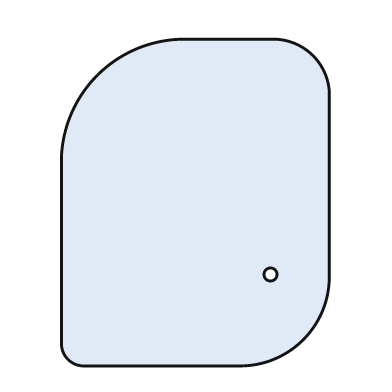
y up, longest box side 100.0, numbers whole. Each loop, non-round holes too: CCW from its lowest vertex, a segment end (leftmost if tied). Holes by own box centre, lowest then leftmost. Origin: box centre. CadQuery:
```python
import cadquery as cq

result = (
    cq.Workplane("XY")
    .moveTo(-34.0, -50.0)
    .lineTo(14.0, -50.0)
    .threePointArc((33.0, -42.0), (41.0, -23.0))
    .lineTo(41.0, 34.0)
    .threePointArc((36.0, 45.0), (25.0, 50.0))
    .lineTo(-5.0, 50.0)
    .threePointArc((-30.0, 39.0), (-41.0, 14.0))
    .lineTo(-41.0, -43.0)
    .threePointArc((-39.0, -48.0), (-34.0, -50.0))
    .close()
    .moveTo(23.0, -22.0)
    .circle(2.0)
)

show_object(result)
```